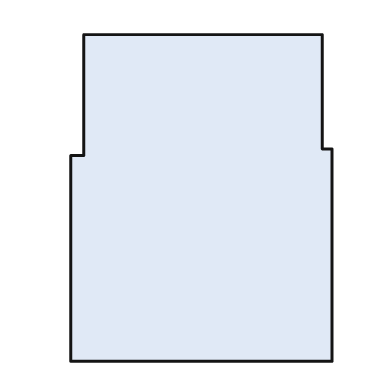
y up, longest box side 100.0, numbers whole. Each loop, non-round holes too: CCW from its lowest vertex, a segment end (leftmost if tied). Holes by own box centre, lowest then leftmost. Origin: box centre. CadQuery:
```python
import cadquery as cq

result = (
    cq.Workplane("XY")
    .moveTo(-40.0, -50.0)
    .lineTo(40.0, -50.0)
    .lineTo(40.0, 15.0)
    .lineTo(37.0, 15.0)
    .lineTo(37.0, 50.0)
    .lineTo(-36.0, 50.0)
    .lineTo(-36.0, 13.0)
    .lineTo(-40.0, 13.0)
    .close()
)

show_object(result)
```